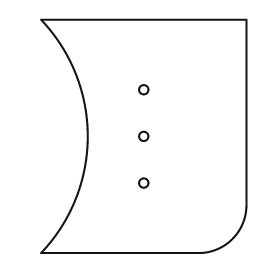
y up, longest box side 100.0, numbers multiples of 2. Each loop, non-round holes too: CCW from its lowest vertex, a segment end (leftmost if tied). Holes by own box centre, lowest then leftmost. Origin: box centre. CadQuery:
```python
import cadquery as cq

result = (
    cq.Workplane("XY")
    .moveTo(-44.0, -50.0)
    .lineTo(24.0, -50.0)
    .threePointArc((38.0, -44.0), (44.0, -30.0))
    .lineTo(44.0, 50.0)
    .lineTo(-44.0, 50.0)
    .threePointArc((-24.0, 0.0), (-44.0, -50.0))
    .close()
    .moveTo(0.0, -20.0)
    .circle(2.0)
    .moveTo(0.0, 0.0)
    .circle(2.0)
    .moveTo(0.0, 20.0)
    .circle(2.0)
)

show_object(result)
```